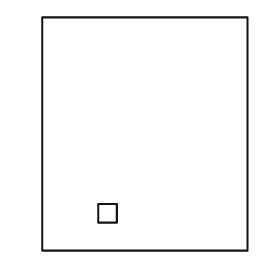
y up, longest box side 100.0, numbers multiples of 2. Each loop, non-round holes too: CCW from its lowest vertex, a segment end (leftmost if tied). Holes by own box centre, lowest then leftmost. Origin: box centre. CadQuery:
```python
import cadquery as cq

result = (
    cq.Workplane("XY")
    .moveTo(-44.0, -50.0)
    .lineTo(44.0, -50.0)
    .lineTo(44.0, 50.0)
    .lineTo(-44.0, 50.0)
    .close()
    .moveTo(-20.0, -38.0)
    .lineTo(-12.0, -38.0)
    .lineTo(-12.0, -30.0)
    .lineTo(-20.0, -30.0)
    .close()
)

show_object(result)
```